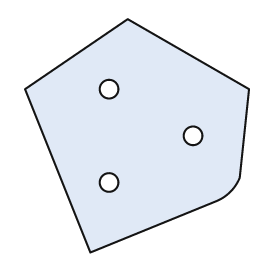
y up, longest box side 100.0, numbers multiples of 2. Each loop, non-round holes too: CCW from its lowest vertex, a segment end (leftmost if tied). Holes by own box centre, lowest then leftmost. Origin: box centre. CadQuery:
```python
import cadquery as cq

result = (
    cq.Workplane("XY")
    .moveTo(-20.0, -50.0)
    .lineTo(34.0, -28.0)
    .threePointArc((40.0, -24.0), (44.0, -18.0))
    .lineTo(48.0, 20.0)
    .lineTo(-4.0, 50.0)
    .lineTo(-48.0, 20.0)
    .close()
    .moveTo(-12.0, -20.0)
    .circle(4.0)
    .moveTo(24.0, 0.0)
    .circle(4.0)
    .moveTo(-12.0, 20.0)
    .circle(4.0)
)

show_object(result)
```